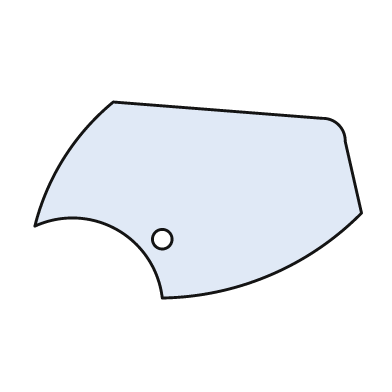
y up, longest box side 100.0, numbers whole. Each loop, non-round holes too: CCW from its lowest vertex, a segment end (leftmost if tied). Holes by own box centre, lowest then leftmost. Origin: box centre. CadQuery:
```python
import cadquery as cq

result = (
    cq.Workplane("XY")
    .moveTo(-11.0, -30.0)
    .threePointArc((22.0, -23.0), (50.0, -4.0))
    .lineTo(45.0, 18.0)
    .threePointArc((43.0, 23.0), (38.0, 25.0))
    .lineTo(-26.0, 30.0)
    .threePointArc((-41.0, 13.0), (-50.0, -8.0))
    .threePointArc((-25.0, -9.0), (-11.0, -30.0))
    .close()
    .moveTo(-11.0, -12.0)
    .circle(3.0)
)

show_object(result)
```